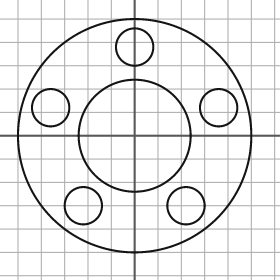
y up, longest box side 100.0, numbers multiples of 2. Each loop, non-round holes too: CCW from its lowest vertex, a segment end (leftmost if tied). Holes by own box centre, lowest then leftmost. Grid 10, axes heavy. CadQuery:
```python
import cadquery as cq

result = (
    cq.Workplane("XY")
    .moveTo(0.0, 0.0)
    .circle(50.0)
    .moveTo(-22.0, -30.0)
    .circle(8.0)
    .moveTo(22.0, -30.0)
    .circle(8.0)
    .moveTo(0.0, 0.0)
    .circle(24.0)
    .moveTo(-36.0, 12.0)
    .circle(8.0)
    .moveTo(36.0, 12.0)
    .circle(8.0)
    .moveTo(0.0, 38.0)
    .circle(8.0)
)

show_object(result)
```